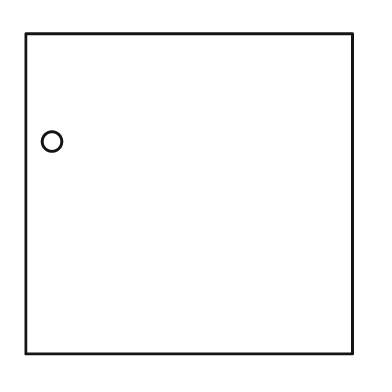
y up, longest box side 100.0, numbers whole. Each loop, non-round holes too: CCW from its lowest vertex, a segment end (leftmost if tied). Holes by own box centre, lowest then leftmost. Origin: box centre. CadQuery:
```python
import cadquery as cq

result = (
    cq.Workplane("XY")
    .moveTo(-50.0, -49.0)
    .lineTo(50.0, -49.0)
    .lineTo(50.0, 49.0)
    .lineTo(-50.0, 49.0)
    .close()
    .moveTo(-42.0, 16.0)
    .circle(3.0)
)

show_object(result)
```